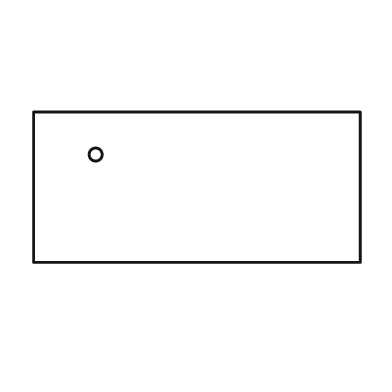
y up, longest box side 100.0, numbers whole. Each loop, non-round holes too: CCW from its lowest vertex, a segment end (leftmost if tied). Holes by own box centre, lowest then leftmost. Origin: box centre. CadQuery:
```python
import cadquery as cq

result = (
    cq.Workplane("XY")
    .moveTo(-50.0, -23.0)
    .lineTo(50.0, -23.0)
    .lineTo(50.0, 23.0)
    .lineTo(-50.0, 23.0)
    .close()
    .moveTo(-31.0, 10.0)
    .circle(2.0)
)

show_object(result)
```